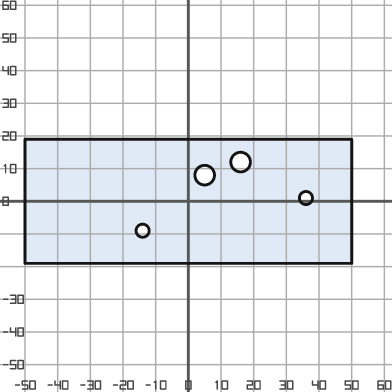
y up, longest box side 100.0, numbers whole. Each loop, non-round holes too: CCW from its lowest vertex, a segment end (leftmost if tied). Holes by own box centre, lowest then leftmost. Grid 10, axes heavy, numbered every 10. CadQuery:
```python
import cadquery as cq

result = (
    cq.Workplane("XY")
    .moveTo(-50.0, -19.0)
    .lineTo(50.0, -19.0)
    .lineTo(50.0, 19.0)
    .lineTo(-50.0, 19.0)
    .close()
    .moveTo(-14.0, -9.0)
    .circle(2.0)
    .moveTo(36.0, 1.0)
    .circle(2.0)
    .moveTo(5.0, 8.0)
    .circle(3.0)
    .moveTo(16.0, 12.0)
    .circle(3.0)
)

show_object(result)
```